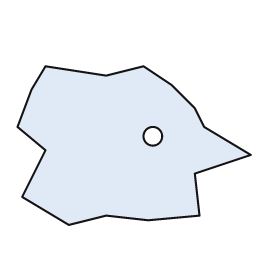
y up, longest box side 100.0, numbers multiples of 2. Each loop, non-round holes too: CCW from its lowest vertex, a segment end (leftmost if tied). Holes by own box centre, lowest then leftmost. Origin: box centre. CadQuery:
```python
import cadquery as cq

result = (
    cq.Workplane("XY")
    .moveTo(-28.0, -34.0)
    .lineTo(-12.0, -30.0)
    .lineTo(6.0, -32.0)
    .lineTo(28.0, -30.0)
    .lineTo(26.0, -12.0)
    .lineTo(50.0, -4.0)
    .lineTo(30.0, 8.0)
    .lineTo(26.0, 16.0)
    .lineTo(16.0, 26.0)
    .lineTo(4.0, 34.0)
    .lineTo(-12.0, 30.0)
    .lineTo(-38.0, 34.0)
    .lineTo(-44.0, 24.0)
    .lineTo(-50.0, 8.0)
    .lineTo(-38.0, -2.0)
    .lineTo(-48.0, -22.0)
    .close()
    .moveTo(8.0, 4.0)
    .circle(4.0)
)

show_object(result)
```